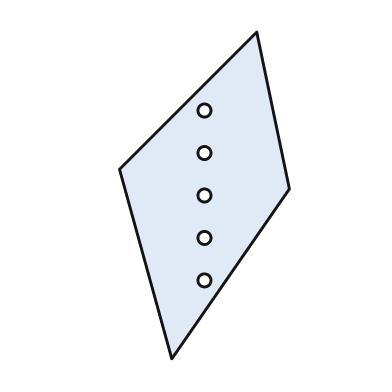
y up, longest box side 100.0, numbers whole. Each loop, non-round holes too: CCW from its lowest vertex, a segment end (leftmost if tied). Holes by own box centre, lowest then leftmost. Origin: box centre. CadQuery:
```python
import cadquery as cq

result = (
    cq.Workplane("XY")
    .moveTo(-10.0, -50.0)
    .lineTo(26.0, 2.0)
    .lineTo(16.0, 50.0)
    .lineTo(-26.0, 8.0)
    .close()
    .moveTo(0.0, -26.0)
    .circle(2.0)
    .moveTo(0.0, -13.0)
    .circle(2.0)
    .moveTo(0.0, 0.0)
    .circle(2.0)
    .moveTo(0.0, 13.0)
    .circle(2.0)
    .moveTo(0.0, 26.0)
    .circle(2.0)
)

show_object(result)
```